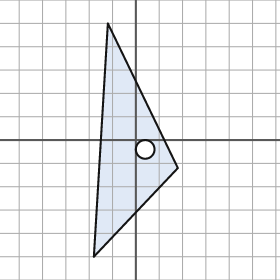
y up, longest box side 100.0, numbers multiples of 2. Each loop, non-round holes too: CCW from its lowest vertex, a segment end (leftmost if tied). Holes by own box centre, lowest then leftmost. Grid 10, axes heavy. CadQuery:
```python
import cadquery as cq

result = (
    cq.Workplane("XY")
    .moveTo(-18.0, -50.0)
    .lineTo(18.0, -12.0)
    .lineTo(-12.0, 50.0)
    .close()
    .moveTo(4.0, -4.0)
    .circle(4.0)
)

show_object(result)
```